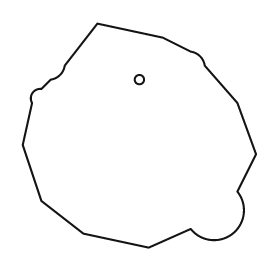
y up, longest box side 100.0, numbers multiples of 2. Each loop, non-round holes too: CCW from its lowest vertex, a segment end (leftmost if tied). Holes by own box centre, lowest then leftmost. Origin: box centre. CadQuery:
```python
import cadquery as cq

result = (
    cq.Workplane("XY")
    .moveTo(4.0, -48.0)
    .lineTo(22.0, -40.0)
    .threePointArc((40.0, -42.0), (42.0, -24.0))
    .lineTo(50.0, -8.0)
    .lineTo(42.0, 14.0)
    .lineTo(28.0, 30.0)
    .threePointArc((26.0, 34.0), (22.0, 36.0))
    .lineTo(10.0, 42.0)
    .lineTo(-18.0, 48.0)
    .lineTo(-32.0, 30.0)
    .threePointArc((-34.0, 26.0), (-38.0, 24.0))
    .lineTo(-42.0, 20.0)
    .threePointArc((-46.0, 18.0), (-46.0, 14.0))
    .lineTo(-50.0, -4.0)
    .lineTo(-42.0, -28.0)
    .lineTo(-24.0, -42.0)
    .close()
    .moveTo(0.0, 24.0)
    .circle(2.0)
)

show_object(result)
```